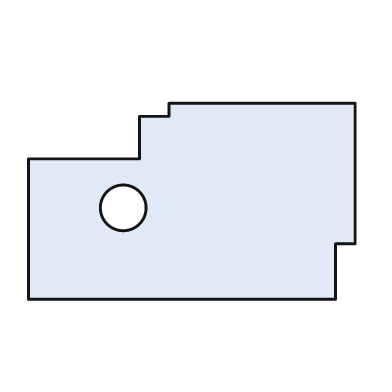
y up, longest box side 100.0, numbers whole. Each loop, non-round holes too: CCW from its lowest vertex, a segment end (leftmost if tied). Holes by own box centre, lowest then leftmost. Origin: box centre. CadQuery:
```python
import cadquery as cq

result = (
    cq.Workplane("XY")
    .moveTo(-50.0, -30.0)
    .lineTo(44.0, -30.0)
    .lineTo(44.0, -13.0)
    .lineTo(50.0, -13.0)
    .lineTo(50.0, 30.0)
    .lineTo(-7.0, 30.0)
    .lineTo(-7.0, 26.0)
    .lineTo(-16.0, 26.0)
    .lineTo(-16.0, 13.0)
    .lineTo(-50.0, 13.0)
    .close()
    .moveTo(-21.0, -2.0)
    .circle(7.0)
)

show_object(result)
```